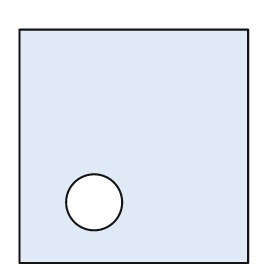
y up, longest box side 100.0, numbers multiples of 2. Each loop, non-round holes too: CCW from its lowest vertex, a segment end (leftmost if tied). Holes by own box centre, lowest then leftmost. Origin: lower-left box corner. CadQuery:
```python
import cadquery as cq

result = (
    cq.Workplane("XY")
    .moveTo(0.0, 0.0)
    .lineTo(98.0, 0.0)
    .lineTo(98.0, 100.0)
    .lineTo(0.0, 100.0)
    .close()
    .moveTo(32.0, 26.0)
    .circle(12.0)
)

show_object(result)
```